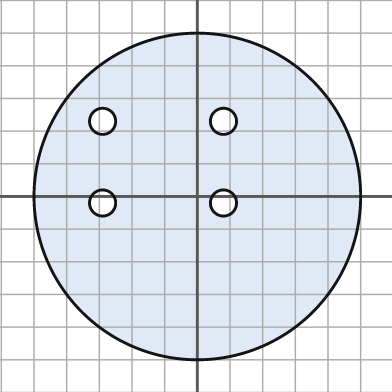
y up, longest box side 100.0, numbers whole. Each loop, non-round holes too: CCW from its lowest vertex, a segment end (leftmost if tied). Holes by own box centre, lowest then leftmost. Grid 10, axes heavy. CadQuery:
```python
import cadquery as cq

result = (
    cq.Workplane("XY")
    .moveTo(0.0, 0.0)
    .circle(50.0)
    .moveTo(-29.0, -2.0)
    .circle(4.0)
    .moveTo(8.0, -2.0)
    .circle(4.0)
    .moveTo(-29.0, 23.0)
    .circle(4.0)
    .moveTo(8.0, 23.0)
    .circle(4.0)
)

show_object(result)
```